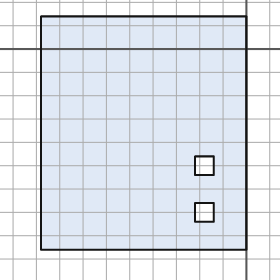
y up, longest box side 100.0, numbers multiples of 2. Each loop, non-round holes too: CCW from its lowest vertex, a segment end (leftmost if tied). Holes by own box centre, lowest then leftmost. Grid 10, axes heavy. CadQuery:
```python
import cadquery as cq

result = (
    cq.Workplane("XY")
    .moveTo(-88.0, -86.0)
    .lineTo(0.0, -86.0)
    .lineTo(0.0, 14.0)
    .lineTo(-88.0, 14.0)
    .close()
    .moveTo(-22.0, -74.0)
    .lineTo(-14.0, -74.0)
    .lineTo(-14.0, -66.0)
    .lineTo(-22.0, -66.0)
    .close()
    .moveTo(-22.0, -54.0)
    .lineTo(-14.0, -54.0)
    .lineTo(-14.0, -46.0)
    .lineTo(-22.0, -46.0)
    .close()
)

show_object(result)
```